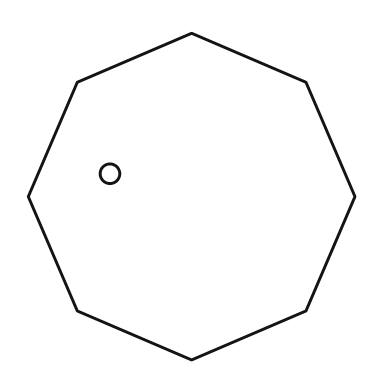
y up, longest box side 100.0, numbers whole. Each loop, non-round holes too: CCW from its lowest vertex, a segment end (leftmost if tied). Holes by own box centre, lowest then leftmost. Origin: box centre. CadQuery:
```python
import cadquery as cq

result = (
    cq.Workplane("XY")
    .moveTo(0.0, -50.0)
    .lineTo(35.0, -35.0)
    .lineTo(50.0, 0.0)
    .lineTo(35.0, 35.0)
    .lineTo(0.0, 50.0)
    .lineTo(-35.0, 35.0)
    .lineTo(-50.0, 0.0)
    .lineTo(-35.0, -35.0)
    .close()
    .moveTo(-25.0, 7.0)
    .circle(3.0)
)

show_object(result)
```